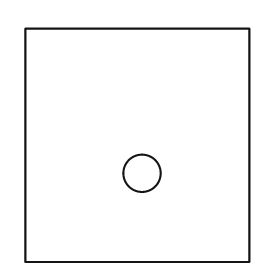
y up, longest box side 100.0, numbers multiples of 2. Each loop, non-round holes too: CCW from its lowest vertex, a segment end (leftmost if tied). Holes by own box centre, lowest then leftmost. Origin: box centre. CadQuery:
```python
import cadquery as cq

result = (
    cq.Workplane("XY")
    .moveTo(-48.0, -50.0)
    .lineTo(48.0, -50.0)
    .lineTo(48.0, 50.0)
    .lineTo(-48.0, 50.0)
    .close()
    .moveTo(2.0, -12.0)
    .circle(8.0)
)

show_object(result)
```